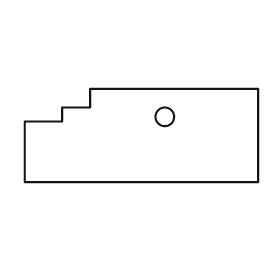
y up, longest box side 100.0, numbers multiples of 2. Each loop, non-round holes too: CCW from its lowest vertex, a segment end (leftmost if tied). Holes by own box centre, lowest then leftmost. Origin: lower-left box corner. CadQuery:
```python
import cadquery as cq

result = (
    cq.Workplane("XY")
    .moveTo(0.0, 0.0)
    .lineTo(100.0, 0.0)
    .lineTo(100.0, 40.0)
    .lineTo(28.0, 40.0)
    .lineTo(28.0, 32.0)
    .lineTo(16.0, 32.0)
    .lineTo(16.0, 26.0)
    .lineTo(0.0, 26.0)
    .close()
    .moveTo(60.0, 28.0)
    .circle(4.0)
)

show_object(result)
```